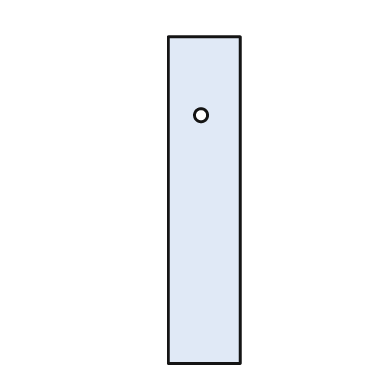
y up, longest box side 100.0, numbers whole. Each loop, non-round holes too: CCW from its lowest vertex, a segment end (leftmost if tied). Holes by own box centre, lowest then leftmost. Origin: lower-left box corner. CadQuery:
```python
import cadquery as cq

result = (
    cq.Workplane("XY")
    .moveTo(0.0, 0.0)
    .lineTo(22.0, 0.0)
    .lineTo(22.0, 100.0)
    .lineTo(0.0, 100.0)
    .close()
    .moveTo(10.0, 76.0)
    .circle(2.0)
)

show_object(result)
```